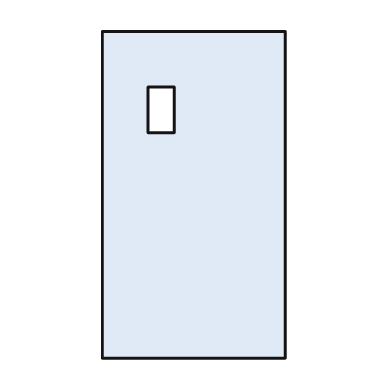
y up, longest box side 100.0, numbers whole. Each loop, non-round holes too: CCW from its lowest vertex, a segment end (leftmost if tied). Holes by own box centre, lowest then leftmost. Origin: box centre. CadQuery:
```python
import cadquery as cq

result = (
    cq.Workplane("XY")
    .moveTo(-28.0, -50.0)
    .lineTo(28.0, -50.0)
    .lineTo(28.0, 50.0)
    .lineTo(-28.0, 50.0)
    .close()
    .moveTo(-14.0, 19.0)
    .lineTo(-6.0, 19.0)
    .lineTo(-6.0, 33.0)
    .lineTo(-14.0, 33.0)
    .close()
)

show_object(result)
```